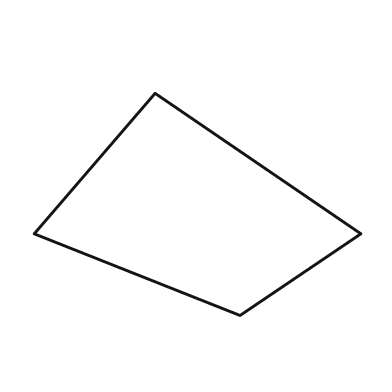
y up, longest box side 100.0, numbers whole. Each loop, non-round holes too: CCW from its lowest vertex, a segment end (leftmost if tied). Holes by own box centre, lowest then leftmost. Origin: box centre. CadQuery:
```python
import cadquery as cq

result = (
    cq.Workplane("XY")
    .moveTo(13.0, -34.0)
    .lineTo(50.0, -9.0)
    .lineTo(-13.0, 34.0)
    .lineTo(-50.0, -9.0)
    .close()
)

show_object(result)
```